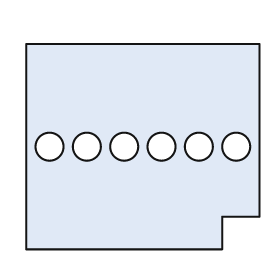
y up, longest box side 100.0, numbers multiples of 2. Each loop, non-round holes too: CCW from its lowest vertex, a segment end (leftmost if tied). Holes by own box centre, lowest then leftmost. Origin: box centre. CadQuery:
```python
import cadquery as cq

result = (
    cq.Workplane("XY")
    .moveTo(-50.0, -44.0)
    .lineTo(34.0, -44.0)
    .lineTo(34.0, -30.0)
    .lineTo(50.0, -30.0)
    .lineTo(50.0, 44.0)
    .lineTo(-50.0, 44.0)
    .close()
    .moveTo(-40.0, 0.0)
    .circle(6.0)
    .moveTo(-24.0, 0.0)
    .circle(6.0)
    .moveTo(-8.0, 0.0)
    .circle(6.0)
    .moveTo(8.0, 0.0)
    .circle(6.0)
    .moveTo(24.0, 0.0)
    .circle(6.0)
    .moveTo(40.0, 0.0)
    .circle(6.0)
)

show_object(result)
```